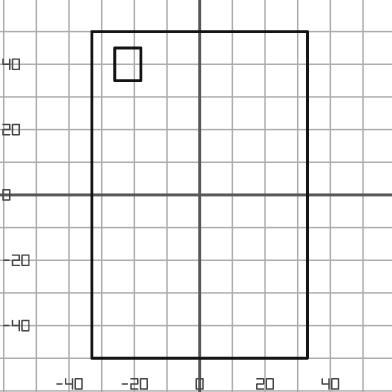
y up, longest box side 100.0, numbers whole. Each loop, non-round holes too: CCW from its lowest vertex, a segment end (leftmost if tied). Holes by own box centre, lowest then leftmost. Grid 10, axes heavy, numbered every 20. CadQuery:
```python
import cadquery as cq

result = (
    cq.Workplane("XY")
    .moveTo(-33.0, -50.0)
    .lineTo(33.0, -50.0)
    .lineTo(33.0, 50.0)
    .lineTo(-33.0, 50.0)
    .close()
    .moveTo(-26.0, 35.0)
    .lineTo(-18.0, 35.0)
    .lineTo(-18.0, 45.0)
    .lineTo(-26.0, 45.0)
    .close()
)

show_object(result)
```